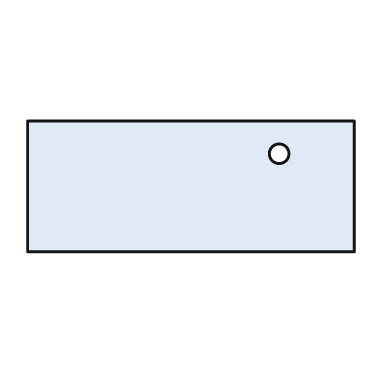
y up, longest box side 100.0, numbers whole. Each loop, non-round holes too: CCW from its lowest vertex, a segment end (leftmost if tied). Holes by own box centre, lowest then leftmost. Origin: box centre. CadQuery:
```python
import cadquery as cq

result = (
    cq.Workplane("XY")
    .moveTo(-50.0, -20.0)
    .lineTo(50.0, -20.0)
    .lineTo(50.0, 20.0)
    .lineTo(-50.0, 20.0)
    .close()
    .moveTo(27.0, 10.0)
    .circle(3.0)
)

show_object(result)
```